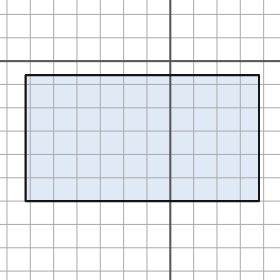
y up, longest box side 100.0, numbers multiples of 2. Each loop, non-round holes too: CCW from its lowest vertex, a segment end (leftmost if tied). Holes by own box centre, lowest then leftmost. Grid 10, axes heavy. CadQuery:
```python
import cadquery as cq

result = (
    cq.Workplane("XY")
    .moveTo(-62.0, -60.0)
    .lineTo(38.0, -60.0)
    .lineTo(38.0, -6.0)
    .lineTo(-62.0, -6.0)
    .close()
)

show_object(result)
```